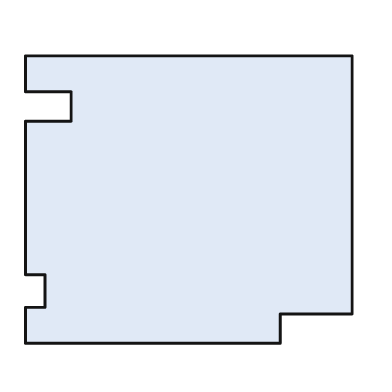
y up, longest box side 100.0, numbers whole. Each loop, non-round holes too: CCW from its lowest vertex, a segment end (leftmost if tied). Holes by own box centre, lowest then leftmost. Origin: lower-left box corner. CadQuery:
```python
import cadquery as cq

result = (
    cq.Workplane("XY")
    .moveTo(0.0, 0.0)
    .lineTo(78.0, 0.0)
    .lineTo(78.0, 9.0)
    .lineTo(100.0, 9.0)
    .lineTo(100.0, 88.0)
    .lineTo(0.0, 88.0)
    .lineTo(0.0, 77.0)
    .lineTo(14.0, 77.0)
    .lineTo(14.0, 68.0)
    .lineTo(0.0, 68.0)
    .lineTo(0.0, 21.0)
    .lineTo(6.0, 21.0)
    .lineTo(6.0, 11.0)
    .lineTo(0.0, 11.0)
    .close()
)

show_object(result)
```